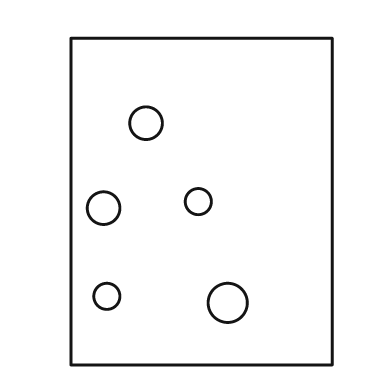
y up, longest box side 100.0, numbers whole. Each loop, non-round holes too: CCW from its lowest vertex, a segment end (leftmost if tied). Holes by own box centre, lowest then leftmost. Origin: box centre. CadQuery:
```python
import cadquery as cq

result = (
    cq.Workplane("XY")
    .moveTo(-40.0, -50.0)
    .lineTo(40.0, -50.0)
    .lineTo(40.0, 50.0)
    .lineTo(-40.0, 50.0)
    .close()
    .moveTo(8.0, -31.0)
    .circle(6.0)
    .moveTo(-29.0, -29.0)
    .circle(4.0)
    .moveTo(-30.0, -2.0)
    .circle(5.0)
    .moveTo(-1.0, 0.0)
    .circle(4.0)
    .moveTo(-17.0, 24.0)
    .circle(5.0)
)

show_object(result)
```